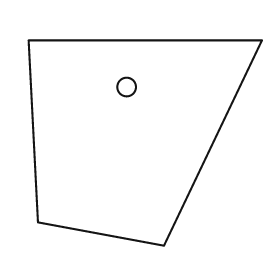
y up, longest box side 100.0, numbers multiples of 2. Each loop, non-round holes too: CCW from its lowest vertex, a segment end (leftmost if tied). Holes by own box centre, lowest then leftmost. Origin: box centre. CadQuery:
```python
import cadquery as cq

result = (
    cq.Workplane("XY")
    .moveTo(8.0, -44.0)
    .lineTo(50.0, 44.0)
    .lineTo(-50.0, 44.0)
    .lineTo(-46.0, -34.0)
    .close()
    .moveTo(-8.0, 24.0)
    .circle(4.0)
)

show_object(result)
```